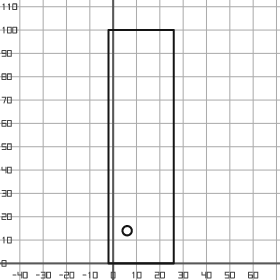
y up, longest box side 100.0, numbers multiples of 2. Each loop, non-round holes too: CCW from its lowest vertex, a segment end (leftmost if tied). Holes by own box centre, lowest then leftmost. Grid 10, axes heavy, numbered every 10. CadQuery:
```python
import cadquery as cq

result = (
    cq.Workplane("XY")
    .moveTo(-2.0, 0.0)
    .lineTo(26.0, 0.0)
    .lineTo(26.0, 100.0)
    .lineTo(-2.0, 100.0)
    .close()
    .moveTo(6.0, 14.0)
    .circle(2.0)
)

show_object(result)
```